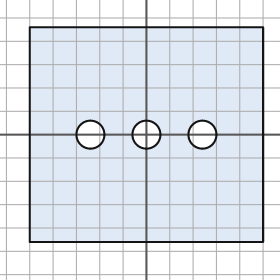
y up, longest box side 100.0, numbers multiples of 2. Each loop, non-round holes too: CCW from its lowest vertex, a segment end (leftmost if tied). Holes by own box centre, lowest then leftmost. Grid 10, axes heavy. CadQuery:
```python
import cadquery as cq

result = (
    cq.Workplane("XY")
    .moveTo(-50.0, -46.0)
    .lineTo(50.0, -46.0)
    .lineTo(50.0, 46.0)
    .lineTo(-50.0, 46.0)
    .close()
    .moveTo(-24.0, 0.0)
    .circle(6.0)
    .moveTo(0.0, 0.0)
    .circle(6.0)
    .moveTo(24.0, 0.0)
    .circle(6.0)
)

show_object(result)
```